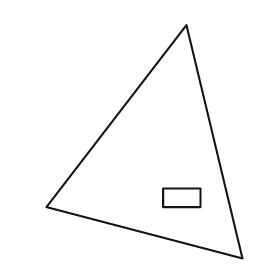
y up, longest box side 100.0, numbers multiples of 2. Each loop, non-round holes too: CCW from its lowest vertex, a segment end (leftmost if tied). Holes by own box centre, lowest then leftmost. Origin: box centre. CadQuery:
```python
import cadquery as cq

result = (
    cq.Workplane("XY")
    .moveTo(42.0, -50.0)
    .lineTo(18.0, 50.0)
    .lineTo(-42.0, -28.0)
    .close()
    .moveTo(8.0, -28.0)
    .lineTo(24.0, -28.0)
    .lineTo(24.0, -20.0)
    .lineTo(8.0, -20.0)
    .close()
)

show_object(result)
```